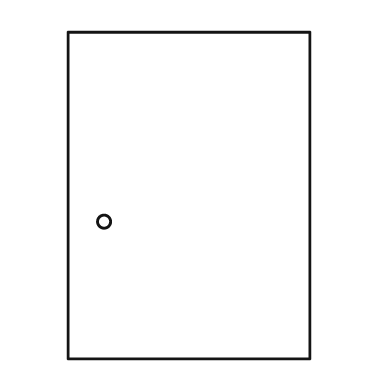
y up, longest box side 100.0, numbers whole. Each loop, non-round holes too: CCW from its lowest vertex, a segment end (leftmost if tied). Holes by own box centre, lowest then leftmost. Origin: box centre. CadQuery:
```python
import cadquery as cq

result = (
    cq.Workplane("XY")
    .moveTo(-37.0, -50.0)
    .lineTo(37.0, -50.0)
    .lineTo(37.0, 50.0)
    .lineTo(-37.0, 50.0)
    .close()
    .moveTo(-26.0, -8.0)
    .circle(2.0)
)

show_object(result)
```